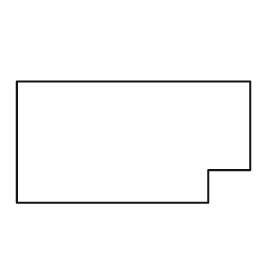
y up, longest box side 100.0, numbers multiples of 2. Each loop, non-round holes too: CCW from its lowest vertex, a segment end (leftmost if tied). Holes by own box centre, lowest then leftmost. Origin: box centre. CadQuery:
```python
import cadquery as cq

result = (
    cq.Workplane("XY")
    .moveTo(-50.0, -26.0)
    .lineTo(32.0, -26.0)
    .lineTo(32.0, -12.0)
    .lineTo(50.0, -12.0)
    .lineTo(50.0, 26.0)
    .lineTo(-50.0, 26.0)
    .close()
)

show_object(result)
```